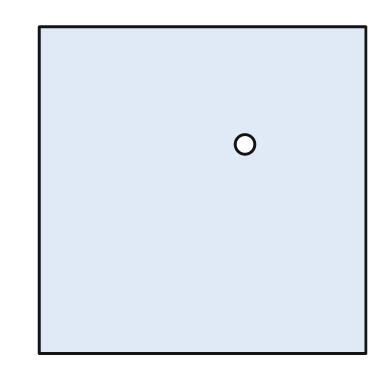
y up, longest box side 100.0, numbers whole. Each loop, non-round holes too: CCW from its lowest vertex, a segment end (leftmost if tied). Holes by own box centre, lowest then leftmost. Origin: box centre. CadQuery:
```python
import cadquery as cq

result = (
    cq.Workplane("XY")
    .moveTo(-50.0, -50.0)
    .lineTo(50.0, -50.0)
    .lineTo(50.0, 50.0)
    .lineTo(-50.0, 50.0)
    .close()
    .moveTo(13.0, 14.0)
    .circle(3.0)
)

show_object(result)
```